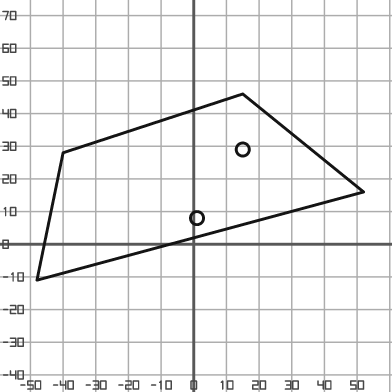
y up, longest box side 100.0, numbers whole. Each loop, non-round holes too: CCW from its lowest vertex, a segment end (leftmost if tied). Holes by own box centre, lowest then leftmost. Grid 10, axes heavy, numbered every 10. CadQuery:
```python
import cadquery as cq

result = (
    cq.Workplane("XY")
    .moveTo(-48.0, -11.0)
    .lineTo(52.0, 16.0)
    .lineTo(15.0, 46.0)
    .lineTo(-40.0, 28.0)
    .close()
    .moveTo(1.0, 8.0)
    .circle(2.0)
    .moveTo(15.0, 29.0)
    .circle(2.0)
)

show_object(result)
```